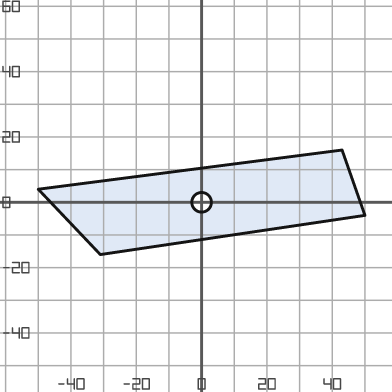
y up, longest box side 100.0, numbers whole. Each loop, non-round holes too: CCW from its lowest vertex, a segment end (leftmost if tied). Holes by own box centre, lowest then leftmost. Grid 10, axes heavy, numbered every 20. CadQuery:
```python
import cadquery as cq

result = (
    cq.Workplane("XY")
    .moveTo(-31.0, -16.0)
    .lineTo(50.0, -4.0)
    .lineTo(43.0, 16.0)
    .lineTo(-50.0, 4.0)
    .close()
    .moveTo(0.0, 0.0)
    .circle(3.0)
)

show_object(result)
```